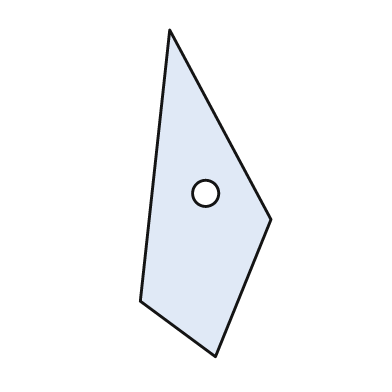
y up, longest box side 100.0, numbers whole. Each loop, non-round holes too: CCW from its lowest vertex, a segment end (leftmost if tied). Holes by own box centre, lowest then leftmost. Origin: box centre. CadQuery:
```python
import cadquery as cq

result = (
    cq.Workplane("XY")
    .moveTo(3.0, -50.0)
    .lineTo(20.0, -8.0)
    .lineTo(-11.0, 50.0)
    .lineTo(-20.0, -33.0)
    .close()
    .moveTo(0.0, 0.0)
    .circle(4.0)
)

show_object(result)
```